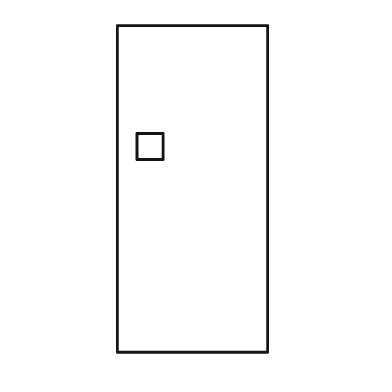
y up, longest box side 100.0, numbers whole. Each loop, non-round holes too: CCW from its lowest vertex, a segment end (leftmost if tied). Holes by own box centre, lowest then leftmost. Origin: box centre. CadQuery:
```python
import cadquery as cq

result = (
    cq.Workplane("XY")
    .moveTo(-23.0, -50.0)
    .lineTo(23.0, -50.0)
    .lineTo(23.0, 50.0)
    .lineTo(-23.0, 50.0)
    .close()
    .moveTo(-17.0, 9.0)
    .lineTo(-9.0, 9.0)
    .lineTo(-9.0, 17.0)
    .lineTo(-17.0, 17.0)
    .close()
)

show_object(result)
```